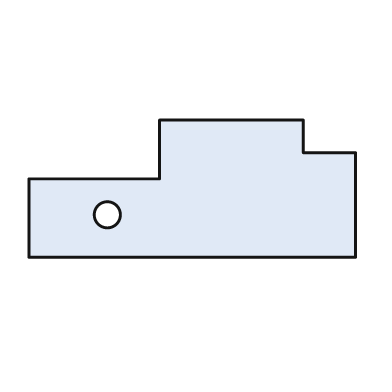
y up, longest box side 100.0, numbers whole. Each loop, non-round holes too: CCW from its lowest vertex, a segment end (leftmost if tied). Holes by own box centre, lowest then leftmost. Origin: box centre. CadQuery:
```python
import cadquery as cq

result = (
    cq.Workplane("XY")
    .moveTo(-50.0, -21.0)
    .lineTo(50.0, -21.0)
    .lineTo(50.0, 11.0)
    .lineTo(34.0, 11.0)
    .lineTo(34.0, 21.0)
    .lineTo(-10.0, 21.0)
    .lineTo(-10.0, 3.0)
    .lineTo(-50.0, 3.0)
    .close()
    .moveTo(-26.0, -8.0)
    .circle(4.0)
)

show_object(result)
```